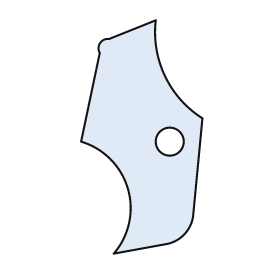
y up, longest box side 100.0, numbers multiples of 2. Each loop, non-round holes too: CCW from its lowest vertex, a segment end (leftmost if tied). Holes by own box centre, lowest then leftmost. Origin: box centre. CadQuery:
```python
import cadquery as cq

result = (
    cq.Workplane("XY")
    .moveTo(-12.0, -50.0)
    .lineTo(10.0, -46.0)
    .threePointArc((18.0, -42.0), (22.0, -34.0))
    .lineTo(26.0, 8.0)
    .threePointArc((10.0, 26.0), (6.0, 50.0))
    .lineTo(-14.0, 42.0)
    .threePointArc((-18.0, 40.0), (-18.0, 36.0))
    .lineTo(-26.0, -2.0)
    .threePointArc((-6.0, -22.0), (-12.0, -50.0))
    .close()
    .moveTo(12.0, -2.0)
    .circle(6.0)
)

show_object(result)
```